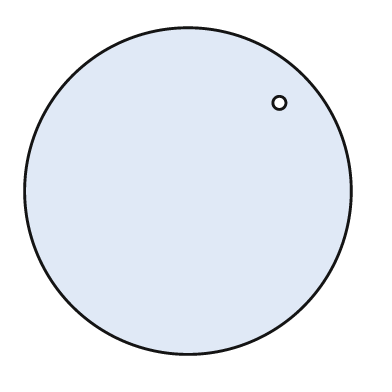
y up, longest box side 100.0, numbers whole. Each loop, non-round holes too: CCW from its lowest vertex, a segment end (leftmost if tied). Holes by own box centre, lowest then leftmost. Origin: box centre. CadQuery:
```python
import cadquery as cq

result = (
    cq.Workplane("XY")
    .moveTo(0.0, 0.0)
    .circle(50.0)
    .moveTo(28.0, 27.0)
    .circle(2.0)
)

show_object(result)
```